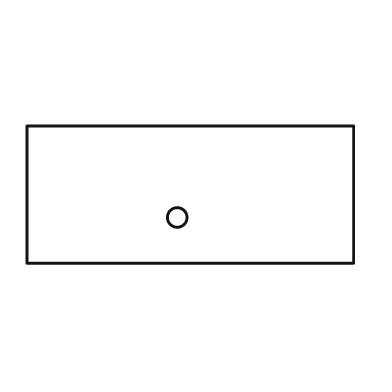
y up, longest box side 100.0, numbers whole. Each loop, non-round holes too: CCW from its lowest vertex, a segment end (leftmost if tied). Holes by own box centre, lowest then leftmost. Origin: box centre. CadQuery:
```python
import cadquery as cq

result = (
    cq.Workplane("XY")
    .moveTo(-50.0, -21.0)
    .lineTo(50.0, -21.0)
    .lineTo(50.0, 21.0)
    .lineTo(-50.0, 21.0)
    .close()
    .moveTo(-4.0, -7.0)
    .circle(3.0)
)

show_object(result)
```